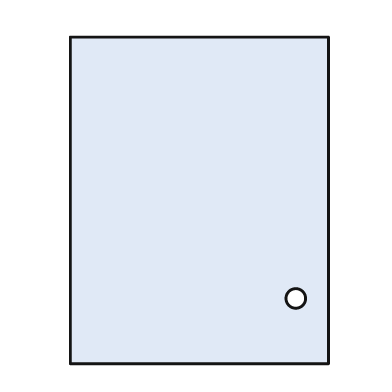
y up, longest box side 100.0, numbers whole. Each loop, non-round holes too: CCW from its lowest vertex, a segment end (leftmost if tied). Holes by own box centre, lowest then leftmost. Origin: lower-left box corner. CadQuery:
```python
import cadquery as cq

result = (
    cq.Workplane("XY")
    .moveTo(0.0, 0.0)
    .lineTo(79.0, 0.0)
    .lineTo(79.0, 100.0)
    .lineTo(0.0, 100.0)
    .close()
    .moveTo(69.0, 20.0)
    .circle(3.0)
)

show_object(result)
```